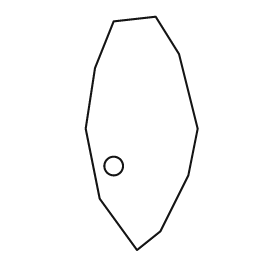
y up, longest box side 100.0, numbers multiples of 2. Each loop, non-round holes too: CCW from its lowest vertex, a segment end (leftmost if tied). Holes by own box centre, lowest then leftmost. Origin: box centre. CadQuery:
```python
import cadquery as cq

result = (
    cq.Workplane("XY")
    .moveTo(-2.0, -50.0)
    .lineTo(8.0, -42.0)
    .lineTo(20.0, -18.0)
    .lineTo(24.0, 2.0)
    .lineTo(16.0, 34.0)
    .lineTo(6.0, 50.0)
    .lineTo(-12.0, 48.0)
    .lineTo(-20.0, 28.0)
    .lineTo(-24.0, 2.0)
    .lineTo(-18.0, -28.0)
    .close()
    .moveTo(-12.0, -14.0)
    .circle(4.0)
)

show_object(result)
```